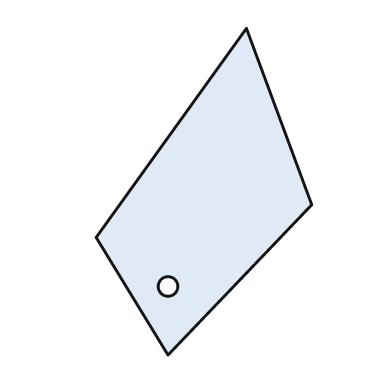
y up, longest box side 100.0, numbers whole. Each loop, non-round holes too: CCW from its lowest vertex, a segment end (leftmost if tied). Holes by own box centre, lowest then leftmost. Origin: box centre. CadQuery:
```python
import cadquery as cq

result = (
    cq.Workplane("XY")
    .moveTo(-11.0, -50.0)
    .lineTo(33.0, -4.0)
    .lineTo(13.0, 50.0)
    .lineTo(-33.0, -14.0)
    .close()
    .moveTo(-11.0, -29.0)
    .circle(3.0)
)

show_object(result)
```